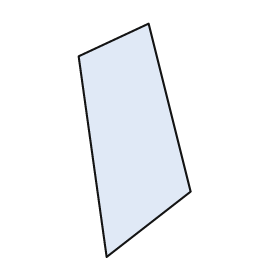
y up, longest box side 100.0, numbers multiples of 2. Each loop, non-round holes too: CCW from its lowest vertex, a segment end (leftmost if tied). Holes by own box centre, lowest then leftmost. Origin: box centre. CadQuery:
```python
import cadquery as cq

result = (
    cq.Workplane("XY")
    .moveTo(-12.0, -50.0)
    .lineTo(24.0, -22.0)
    .lineTo(6.0, 50.0)
    .lineTo(-24.0, 36.0)
    .close()
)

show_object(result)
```